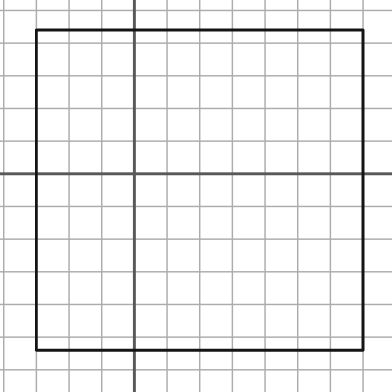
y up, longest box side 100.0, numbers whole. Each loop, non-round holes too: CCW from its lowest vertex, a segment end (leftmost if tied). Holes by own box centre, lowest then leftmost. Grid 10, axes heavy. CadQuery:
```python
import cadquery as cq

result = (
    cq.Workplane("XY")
    .moveTo(-30.0, -54.0)
    .lineTo(70.0, -54.0)
    .lineTo(70.0, 44.0)
    .lineTo(-30.0, 44.0)
    .close()
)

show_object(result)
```